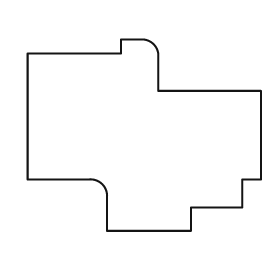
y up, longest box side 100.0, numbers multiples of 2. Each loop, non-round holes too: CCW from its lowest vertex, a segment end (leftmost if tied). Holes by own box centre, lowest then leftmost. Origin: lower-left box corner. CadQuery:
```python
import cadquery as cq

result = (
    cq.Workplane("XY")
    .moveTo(34.0, 0.0)
    .lineTo(70.0, 0.0)
    .lineTo(70.0, 10.0)
    .lineTo(92.0, 10.0)
    .lineTo(92.0, 22.0)
    .lineTo(100.0, 22.0)
    .lineTo(100.0, 60.0)
    .lineTo(56.0, 60.0)
    .lineTo(56.0, 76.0)
    .threePointArc((54.0, 80.0), (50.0, 82.0))
    .lineTo(40.0, 82.0)
    .lineTo(40.0, 76.0)
    .lineTo(0.0, 76.0)
    .lineTo(0.0, 22.0)
    .lineTo(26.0, 22.0)
    .threePointArc((32.0, 20.0), (34.0, 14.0))
    .close()
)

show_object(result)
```